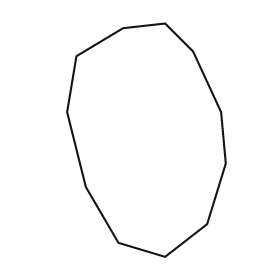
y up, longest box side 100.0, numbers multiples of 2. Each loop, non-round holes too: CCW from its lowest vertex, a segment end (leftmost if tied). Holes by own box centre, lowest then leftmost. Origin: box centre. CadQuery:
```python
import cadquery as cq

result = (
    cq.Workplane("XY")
    .moveTo(8.0, -50.0)
    .lineTo(26.0, -36.0)
    .lineTo(34.0, -10.0)
    .lineTo(32.0, 12.0)
    .lineTo(20.0, 38.0)
    .lineTo(8.0, 50.0)
    .lineTo(-10.0, 48.0)
    .lineTo(-30.0, 36.0)
    .lineTo(-34.0, 12.0)
    .lineTo(-26.0, -20.0)
    .lineTo(-12.0, -44.0)
    .close()
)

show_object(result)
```